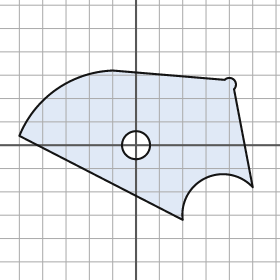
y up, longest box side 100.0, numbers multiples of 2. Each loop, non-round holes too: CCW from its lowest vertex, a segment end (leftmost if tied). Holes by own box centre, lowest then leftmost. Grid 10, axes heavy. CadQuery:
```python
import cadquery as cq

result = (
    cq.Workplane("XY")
    .moveTo(20.0, -32.0)
    .threePointArc((30.0, -14.0), (50.0, -18.0))
    .lineTo(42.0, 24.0)
    .threePointArc((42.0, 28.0), (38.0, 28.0))
    .lineTo(-10.0, 32.0)
    .threePointArc((-34.0, 24.0), (-50.0, 4.0))
    .close()
    .moveTo(0.0, 0.0)
    .circle(6.0)
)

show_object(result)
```